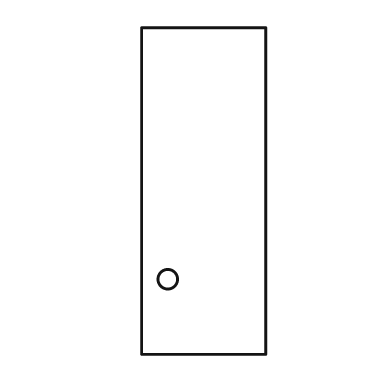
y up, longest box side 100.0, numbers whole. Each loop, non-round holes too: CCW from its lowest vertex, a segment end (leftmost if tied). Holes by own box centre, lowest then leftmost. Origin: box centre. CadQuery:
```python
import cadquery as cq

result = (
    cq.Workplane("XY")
    .moveTo(-19.0, -50.0)
    .lineTo(19.0, -50.0)
    .lineTo(19.0, 50.0)
    .lineTo(-19.0, 50.0)
    .close()
    .moveTo(-11.0, -27.0)
    .circle(3.0)
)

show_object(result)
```